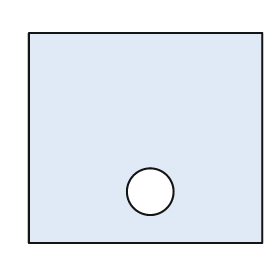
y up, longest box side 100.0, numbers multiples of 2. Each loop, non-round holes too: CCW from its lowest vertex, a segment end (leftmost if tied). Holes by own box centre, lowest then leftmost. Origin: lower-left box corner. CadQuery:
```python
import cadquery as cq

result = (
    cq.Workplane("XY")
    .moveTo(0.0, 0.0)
    .lineTo(100.0, 0.0)
    .lineTo(100.0, 90.0)
    .lineTo(0.0, 90.0)
    .close()
    .moveTo(52.0, 22.0)
    .circle(10.0)
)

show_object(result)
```